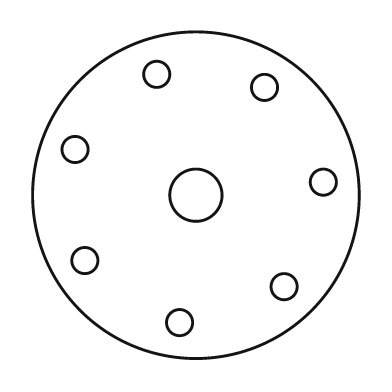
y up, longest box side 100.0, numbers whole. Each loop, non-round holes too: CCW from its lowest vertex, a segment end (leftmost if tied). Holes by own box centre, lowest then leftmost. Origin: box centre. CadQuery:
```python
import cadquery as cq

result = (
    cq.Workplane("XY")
    .moveTo(0.0, 0.0)
    .circle(50.0)
    .moveTo(-5.0, -39.0)
    .circle(4.0)
    .moveTo(27.0, -28.0)
    .circle(4.0)
    .moveTo(-34.0, -20.0)
    .circle(4.0)
    .moveTo(0.0, 0.0)
    .circle(8.0)
    .moveTo(39.0, 4.0)
    .circle(4.0)
    .moveTo(-37.0, 14.0)
    .circle(4.0)
    .moveTo(21.0, 33.0)
    .circle(4.0)
    .moveTo(-12.0, 37.0)
    .circle(4.0)
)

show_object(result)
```